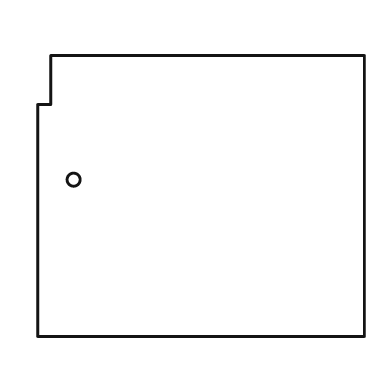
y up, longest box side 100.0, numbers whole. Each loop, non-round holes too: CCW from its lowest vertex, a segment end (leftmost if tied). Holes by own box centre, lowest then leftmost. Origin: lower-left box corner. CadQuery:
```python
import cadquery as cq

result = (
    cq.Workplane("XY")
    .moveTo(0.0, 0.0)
    .lineTo(100.0, 0.0)
    .lineTo(100.0, 86.0)
    .lineTo(4.0, 86.0)
    .lineTo(4.0, 71.0)
    .lineTo(0.0, 71.0)
    .close()
    .moveTo(11.0, 48.0)
    .circle(2.0)
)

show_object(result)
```